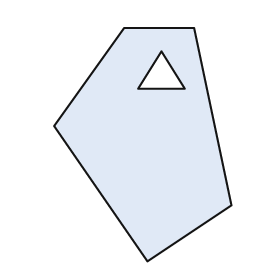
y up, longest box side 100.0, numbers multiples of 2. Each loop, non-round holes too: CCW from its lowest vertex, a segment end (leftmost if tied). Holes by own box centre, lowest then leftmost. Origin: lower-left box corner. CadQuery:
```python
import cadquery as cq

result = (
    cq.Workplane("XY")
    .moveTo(40.0, 0.0)
    .lineTo(76.0, 24.0)
    .lineTo(60.0, 100.0)
    .lineTo(30.0, 100.0)
    .lineTo(0.0, 58.0)
    .close()
    .moveTo(36.0, 74.0)
    .lineTo(56.0, 74.0)
    .lineTo(46.0, 90.0)
    .close()
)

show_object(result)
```